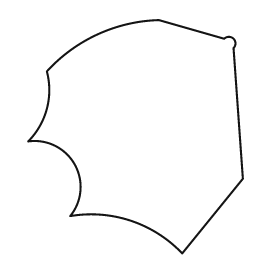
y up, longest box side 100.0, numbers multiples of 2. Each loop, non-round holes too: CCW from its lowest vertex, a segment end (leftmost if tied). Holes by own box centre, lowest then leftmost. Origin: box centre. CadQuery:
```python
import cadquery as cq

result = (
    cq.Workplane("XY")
    .moveTo(20.0, -50.0)
    .lineTo(46.0, -18.0)
    .lineTo(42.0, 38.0)
    .threePointArc((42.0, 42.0), (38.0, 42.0))
    .lineTo(10.0, 50.0)
    .threePointArc((-16.0, 44.0), (-38.0, 28.0))
    .threePointArc((-38.0, 12.0), (-46.0, -2.0))
    .threePointArc((-26.0, -12.0), (-28.0, -34.0))
    .threePointArc((-2.0, -36.0), (20.0, -50.0))
    .close()
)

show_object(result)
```